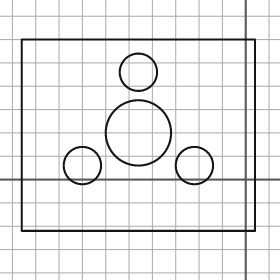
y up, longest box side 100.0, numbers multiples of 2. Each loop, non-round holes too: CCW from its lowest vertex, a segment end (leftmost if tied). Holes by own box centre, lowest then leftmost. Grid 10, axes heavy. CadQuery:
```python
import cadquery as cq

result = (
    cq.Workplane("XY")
    .moveTo(-96.0, -22.0)
    .lineTo(4.0, -22.0)
    .lineTo(4.0, 60.0)
    .lineTo(-96.0, 60.0)
    .close()
    .moveTo(-70.0, 6.0)
    .circle(8.0)
    .moveTo(-22.0, 6.0)
    .circle(8.0)
    .moveTo(-46.0, 20.0)
    .circle(14.0)
    .moveTo(-46.0, 46.0)
    .circle(8.0)
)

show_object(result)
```